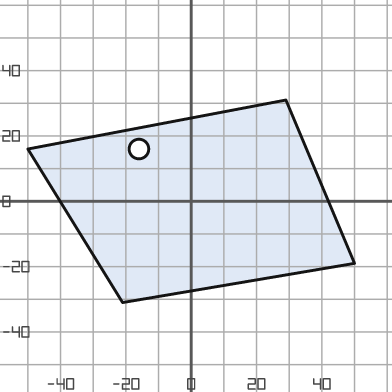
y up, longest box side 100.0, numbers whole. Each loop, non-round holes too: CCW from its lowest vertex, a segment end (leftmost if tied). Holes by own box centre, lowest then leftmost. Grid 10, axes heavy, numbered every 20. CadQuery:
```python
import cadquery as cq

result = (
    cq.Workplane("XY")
    .moveTo(-21.0, -31.0)
    .lineTo(50.0, -19.0)
    .lineTo(29.0, 31.0)
    .lineTo(-50.0, 16.0)
    .close()
    .moveTo(-16.0, 16.0)
    .circle(3.0)
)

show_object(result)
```